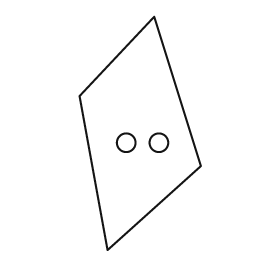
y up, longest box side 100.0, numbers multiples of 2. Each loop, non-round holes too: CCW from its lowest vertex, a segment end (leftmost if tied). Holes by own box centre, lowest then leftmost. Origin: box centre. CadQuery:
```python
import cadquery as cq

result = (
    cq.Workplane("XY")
    .moveTo(-14.0, -50.0)
    .lineTo(26.0, -14.0)
    .lineTo(6.0, 50.0)
    .lineTo(-26.0, 16.0)
    .close()
    .moveTo(-6.0, -4.0)
    .circle(4.0)
    .moveTo(8.0, -4.0)
    .circle(4.0)
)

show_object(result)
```